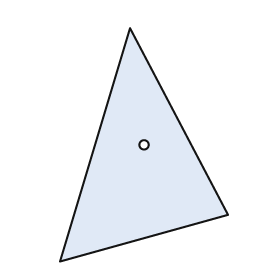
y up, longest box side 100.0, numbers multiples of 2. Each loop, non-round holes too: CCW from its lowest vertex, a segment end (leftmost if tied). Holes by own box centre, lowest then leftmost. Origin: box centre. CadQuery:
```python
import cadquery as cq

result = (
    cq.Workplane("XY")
    .moveTo(-36.0, -50.0)
    .lineTo(36.0, -30.0)
    .lineTo(-6.0, 50.0)
    .close()
    .moveTo(0.0, 0.0)
    .circle(2.0)
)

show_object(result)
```